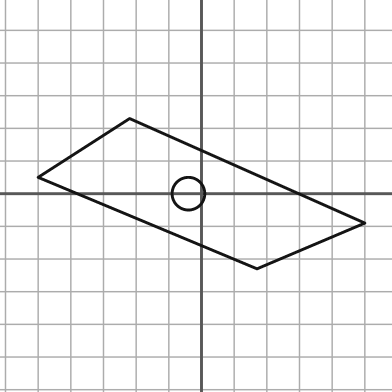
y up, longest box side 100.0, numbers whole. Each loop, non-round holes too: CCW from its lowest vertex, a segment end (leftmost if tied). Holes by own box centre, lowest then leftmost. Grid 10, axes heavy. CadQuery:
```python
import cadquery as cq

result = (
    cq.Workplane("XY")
    .moveTo(17.0, -23.0)
    .lineTo(50.0, -9.0)
    .lineTo(-22.0, 23.0)
    .lineTo(-50.0, 5.0)
    .close()
    .moveTo(-4.0, 0.0)
    .circle(5.0)
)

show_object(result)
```